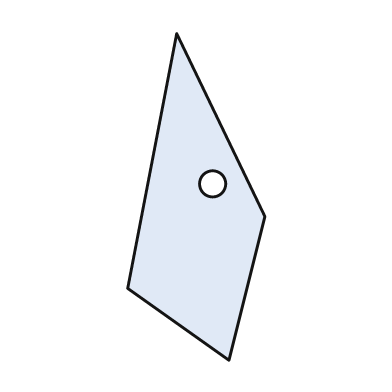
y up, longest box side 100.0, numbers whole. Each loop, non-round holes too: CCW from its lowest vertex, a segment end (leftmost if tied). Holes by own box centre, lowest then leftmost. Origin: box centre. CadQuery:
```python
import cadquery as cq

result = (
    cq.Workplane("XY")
    .moveTo(10.0, -50.0)
    .lineTo(21.0, -6.0)
    .lineTo(-6.0, 50.0)
    .lineTo(-21.0, -28.0)
    .close()
    .moveTo(5.0, 4.0)
    .circle(4.0)
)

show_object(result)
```